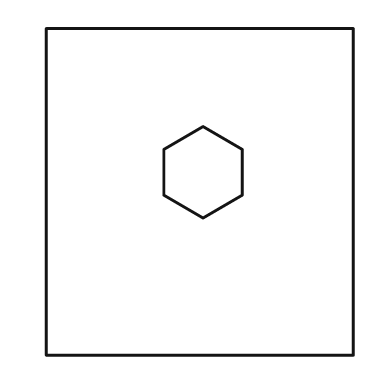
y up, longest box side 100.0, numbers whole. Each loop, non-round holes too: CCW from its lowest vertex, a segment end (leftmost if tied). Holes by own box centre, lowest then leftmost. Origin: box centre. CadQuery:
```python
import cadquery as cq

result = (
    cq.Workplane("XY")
    .moveTo(-47.0, -50.0)
    .lineTo(47.0, -50.0)
    .lineTo(47.0, 50.0)
    .lineTo(-47.0, 50.0)
    .close()
    .moveTo(1.0, -8.0)
    .lineTo(13.0, -1.0)
    .lineTo(13.0, 13.0)
    .lineTo(1.0, 20.0)
    .lineTo(-11.0, 13.0)
    .lineTo(-11.0, -1.0)
    .close()
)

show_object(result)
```